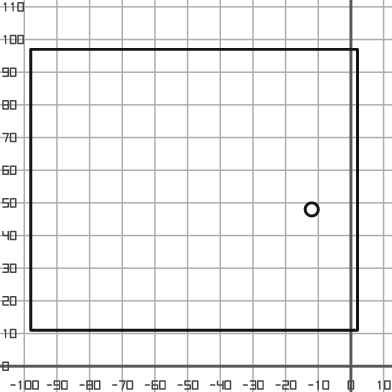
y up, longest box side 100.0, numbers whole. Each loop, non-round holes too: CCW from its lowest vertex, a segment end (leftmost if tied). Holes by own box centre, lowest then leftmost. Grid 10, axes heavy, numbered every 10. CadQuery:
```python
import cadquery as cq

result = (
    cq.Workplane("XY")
    .moveTo(-98.0, 11.0)
    .lineTo(2.0, 11.0)
    .lineTo(2.0, 97.0)
    .lineTo(-98.0, 97.0)
    .close()
    .moveTo(-12.0, 48.0)
    .circle(2.0)
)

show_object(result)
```